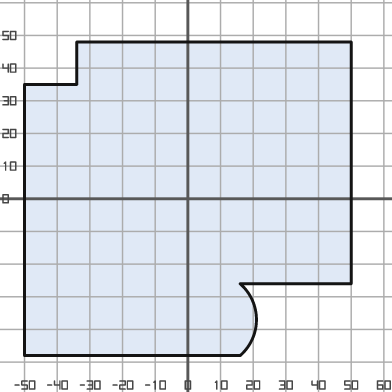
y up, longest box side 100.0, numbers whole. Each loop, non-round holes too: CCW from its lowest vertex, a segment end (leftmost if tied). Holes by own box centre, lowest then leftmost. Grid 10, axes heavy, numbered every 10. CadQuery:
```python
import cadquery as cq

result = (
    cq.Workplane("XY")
    .moveTo(-50.0, -48.0)
    .lineTo(16.0, -48.0)
    .threePointArc((21.0, -37.0), (16.0, -26.0))
    .lineTo(50.0, -26.0)
    .lineTo(50.0, 48.0)
    .lineTo(-34.0, 48.0)
    .lineTo(-34.0, 35.0)
    .lineTo(-50.0, 35.0)
    .close()
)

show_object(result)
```